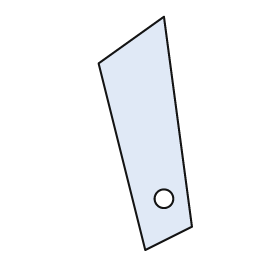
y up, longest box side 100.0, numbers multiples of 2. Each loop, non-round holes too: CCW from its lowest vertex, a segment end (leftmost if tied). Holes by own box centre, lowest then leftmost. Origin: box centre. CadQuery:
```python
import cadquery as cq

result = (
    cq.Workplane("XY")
    .moveTo(0.0, -50.0)
    .lineTo(20.0, -40.0)
    .lineTo(8.0, 50.0)
    .lineTo(-20.0, 30.0)
    .close()
    .moveTo(8.0, -28.0)
    .circle(4.0)
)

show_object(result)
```